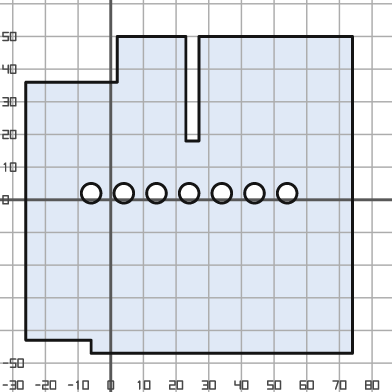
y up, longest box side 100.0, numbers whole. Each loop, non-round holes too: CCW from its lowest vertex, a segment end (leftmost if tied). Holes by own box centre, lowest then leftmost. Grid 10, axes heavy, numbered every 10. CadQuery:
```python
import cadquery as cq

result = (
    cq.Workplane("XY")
    .moveTo(-6.0, -47.0)
    .lineTo(74.0, -47.0)
    .lineTo(74.0, 50.0)
    .lineTo(27.0, 50.0)
    .lineTo(27.0, 18.0)
    .lineTo(23.0, 18.0)
    .lineTo(23.0, 50.0)
    .lineTo(2.0, 50.0)
    .lineTo(2.0, 36.0)
    .lineTo(-26.0, 36.0)
    .lineTo(-26.0, -43.0)
    .lineTo(-6.0, -43.0)
    .close()
    .moveTo(-6.0, 2.0)
    .circle(3.0)
    .moveTo(4.0, 2.0)
    .circle(3.0)
    .moveTo(14.0, 2.0)
    .circle(3.0)
    .moveTo(24.0, 2.0)
    .circle(3.0)
    .moveTo(34.0, 2.0)
    .circle(3.0)
    .moveTo(44.0, 2.0)
    .circle(3.0)
    .moveTo(54.0, 2.0)
    .circle(3.0)
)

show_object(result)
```